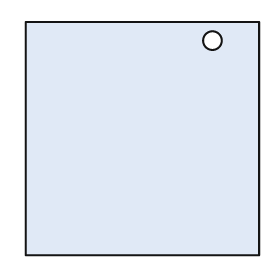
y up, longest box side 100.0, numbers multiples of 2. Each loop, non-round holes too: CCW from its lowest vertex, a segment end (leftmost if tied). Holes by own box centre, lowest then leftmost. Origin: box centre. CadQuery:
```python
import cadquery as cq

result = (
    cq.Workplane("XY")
    .moveTo(-50.0, -50.0)
    .lineTo(50.0, -50.0)
    .lineTo(50.0, 50.0)
    .lineTo(-50.0, 50.0)
    .close()
    .moveTo(30.0, 42.0)
    .circle(4.0)
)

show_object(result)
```